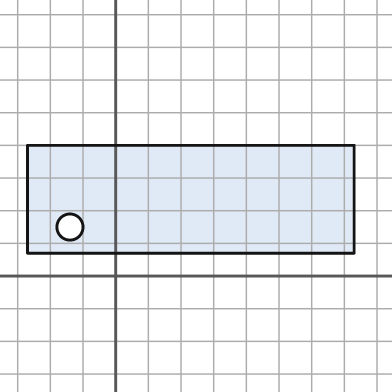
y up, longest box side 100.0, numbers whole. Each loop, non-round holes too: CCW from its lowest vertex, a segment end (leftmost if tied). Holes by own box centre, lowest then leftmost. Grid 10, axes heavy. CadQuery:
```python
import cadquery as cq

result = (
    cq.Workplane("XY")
    .moveTo(-27.0, 7.0)
    .lineTo(73.0, 7.0)
    .lineTo(73.0, 40.0)
    .lineTo(-27.0, 40.0)
    .close()
    .moveTo(-14.0, 15.0)
    .circle(4.0)
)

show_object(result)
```